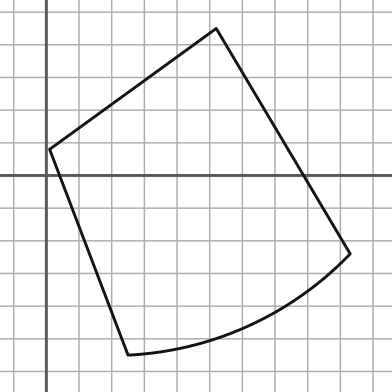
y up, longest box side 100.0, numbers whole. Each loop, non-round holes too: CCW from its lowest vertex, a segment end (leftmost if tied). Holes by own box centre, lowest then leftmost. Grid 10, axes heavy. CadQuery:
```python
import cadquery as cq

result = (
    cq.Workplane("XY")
    .moveTo(25.0, -55.0)
    .threePointArc((62.0, -46.0), (93.0, -24.0))
    .lineTo(52.0, 45.0)
    .lineTo(1.0, 8.0)
    .close()
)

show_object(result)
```